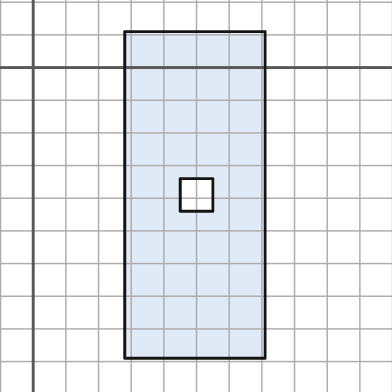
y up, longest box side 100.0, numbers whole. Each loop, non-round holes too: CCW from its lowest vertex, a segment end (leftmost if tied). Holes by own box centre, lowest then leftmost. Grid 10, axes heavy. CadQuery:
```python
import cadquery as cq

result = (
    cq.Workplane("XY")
    .moveTo(28.0, -89.0)
    .lineTo(71.0, -89.0)
    .lineTo(71.0, 11.0)
    .lineTo(28.0, 11.0)
    .close()
    .moveTo(45.0, -44.0)
    .lineTo(55.0, -44.0)
    .lineTo(55.0, -34.0)
    .lineTo(45.0, -34.0)
    .close()
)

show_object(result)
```